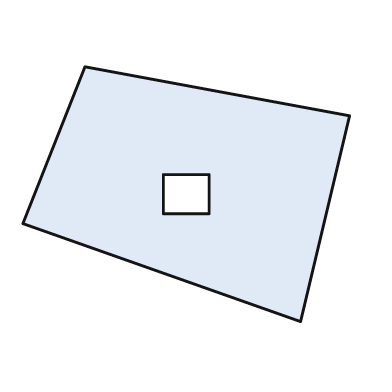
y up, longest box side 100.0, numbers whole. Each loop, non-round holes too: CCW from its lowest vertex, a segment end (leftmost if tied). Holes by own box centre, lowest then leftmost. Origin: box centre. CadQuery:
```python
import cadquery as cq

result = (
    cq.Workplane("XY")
    .moveTo(35.0, -39.0)
    .lineTo(50.0, 24.0)
    .lineTo(-31.0, 39.0)
    .lineTo(-50.0, -9.0)
    .close()
    .moveTo(-7.0, -6.0)
    .lineTo(7.0, -6.0)
    .lineTo(7.0, 6.0)
    .lineTo(-7.0, 6.0)
    .close()
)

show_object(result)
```